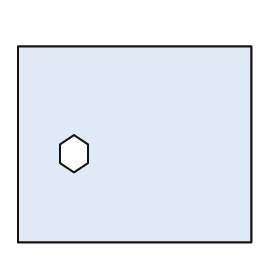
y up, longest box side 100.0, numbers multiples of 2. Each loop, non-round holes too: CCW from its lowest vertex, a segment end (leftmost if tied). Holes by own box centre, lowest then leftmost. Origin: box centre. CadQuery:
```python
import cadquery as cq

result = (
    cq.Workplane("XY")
    .moveTo(-50.0, -42.0)
    .lineTo(50.0, -42.0)
    .lineTo(50.0, 42.0)
    .lineTo(-50.0, 42.0)
    .close()
    .moveTo(-26.0, -12.0)
    .lineTo(-20.0, -8.0)
    .lineTo(-20.0, 0.0)
    .lineTo(-26.0, 4.0)
    .lineTo(-32.0, 0.0)
    .lineTo(-32.0, -8.0)
    .close()
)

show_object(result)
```